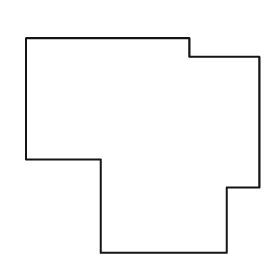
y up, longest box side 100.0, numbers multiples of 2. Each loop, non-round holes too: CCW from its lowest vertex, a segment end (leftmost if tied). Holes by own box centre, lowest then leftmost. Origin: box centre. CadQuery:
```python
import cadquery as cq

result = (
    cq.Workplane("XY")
    .moveTo(-18.0, -46.0)
    .lineTo(36.0, -46.0)
    .lineTo(36.0, -18.0)
    .lineTo(50.0, -18.0)
    .lineTo(50.0, 38.0)
    .lineTo(20.0, 38.0)
    .lineTo(20.0, 46.0)
    .lineTo(-50.0, 46.0)
    .lineTo(-50.0, -6.0)
    .lineTo(-18.0, -6.0)
    .close()
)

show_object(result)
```